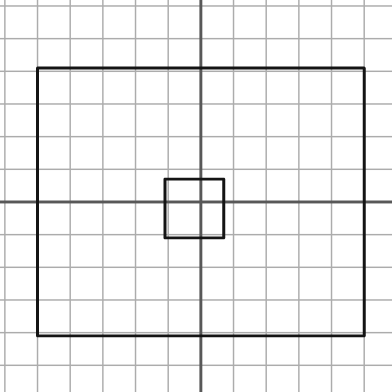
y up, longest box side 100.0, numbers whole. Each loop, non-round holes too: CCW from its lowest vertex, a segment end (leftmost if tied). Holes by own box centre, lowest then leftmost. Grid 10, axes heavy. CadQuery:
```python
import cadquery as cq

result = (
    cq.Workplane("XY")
    .moveTo(-50.0, -41.0)
    .lineTo(50.0, -41.0)
    .lineTo(50.0, 41.0)
    .lineTo(-50.0, 41.0)
    .close()
    .moveTo(-11.0, -11.0)
    .lineTo(7.0, -11.0)
    .lineTo(7.0, 7.0)
    .lineTo(-11.0, 7.0)
    .close()
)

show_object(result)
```